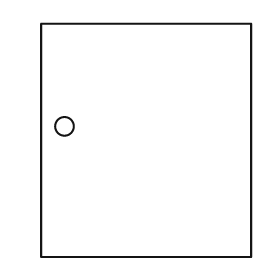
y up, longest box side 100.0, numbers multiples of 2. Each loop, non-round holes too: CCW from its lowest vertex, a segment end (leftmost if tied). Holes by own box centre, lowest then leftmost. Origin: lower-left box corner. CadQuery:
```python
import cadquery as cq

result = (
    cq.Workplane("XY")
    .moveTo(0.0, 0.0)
    .lineTo(90.0, 0.0)
    .lineTo(90.0, 100.0)
    .lineTo(0.0, 100.0)
    .close()
    .moveTo(10.0, 56.0)
    .circle(4.0)
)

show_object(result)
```